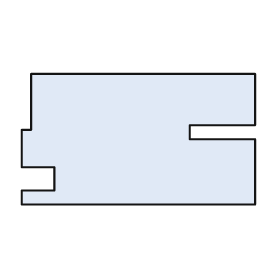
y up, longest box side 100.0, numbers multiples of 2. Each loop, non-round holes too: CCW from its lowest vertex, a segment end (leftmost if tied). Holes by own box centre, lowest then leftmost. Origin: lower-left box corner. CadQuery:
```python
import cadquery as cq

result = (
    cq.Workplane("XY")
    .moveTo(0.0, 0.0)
    .lineTo(100.0, 0.0)
    .lineTo(100.0, 28.0)
    .lineTo(72.0, 28.0)
    .lineTo(72.0, 34.0)
    .lineTo(100.0, 34.0)
    .lineTo(100.0, 56.0)
    .lineTo(4.0, 56.0)
    .lineTo(4.0, 32.0)
    .lineTo(0.0, 32.0)
    .lineTo(0.0, 16.0)
    .lineTo(14.0, 16.0)
    .lineTo(14.0, 6.0)
    .lineTo(0.0, 6.0)
    .close()
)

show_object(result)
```